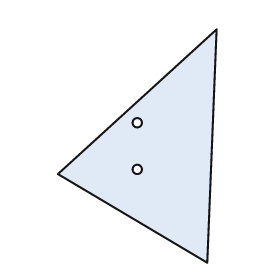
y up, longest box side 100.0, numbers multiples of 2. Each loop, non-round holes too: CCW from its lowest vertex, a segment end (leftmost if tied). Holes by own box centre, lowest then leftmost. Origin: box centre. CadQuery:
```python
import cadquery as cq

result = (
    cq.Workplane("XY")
    .moveTo(30.0, -50.0)
    .lineTo(34.0, 50.0)
    .lineTo(-34.0, -12.0)
    .close()
    .moveTo(0.0, -10.0)
    .circle(2.0)
    .moveTo(0.0, 10.0)
    .circle(2.0)
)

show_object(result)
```